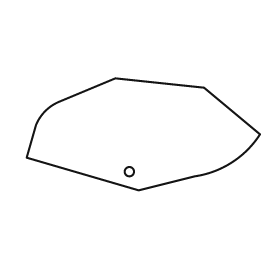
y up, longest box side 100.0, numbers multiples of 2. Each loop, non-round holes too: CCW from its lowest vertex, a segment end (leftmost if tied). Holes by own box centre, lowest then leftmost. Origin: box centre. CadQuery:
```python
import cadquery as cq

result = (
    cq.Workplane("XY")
    .moveTo(-2.0, -24.0)
    .lineTo(22.0, -18.0)
    .threePointArc((38.0, -12.0), (50.0, 0.0))
    .lineTo(26.0, 20.0)
    .lineTo(-12.0, 24.0)
    .lineTo(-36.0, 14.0)
    .threePointArc((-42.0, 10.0), (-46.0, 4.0))
    .lineTo(-50.0, -10.0)
    .close()
    .moveTo(-6.0, -16.0)
    .circle(2.0)
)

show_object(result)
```